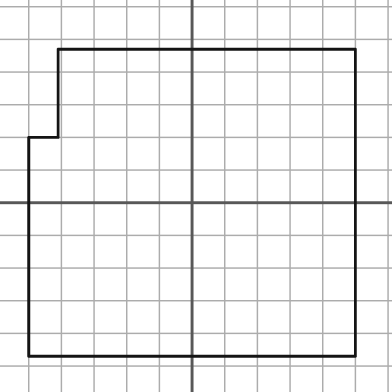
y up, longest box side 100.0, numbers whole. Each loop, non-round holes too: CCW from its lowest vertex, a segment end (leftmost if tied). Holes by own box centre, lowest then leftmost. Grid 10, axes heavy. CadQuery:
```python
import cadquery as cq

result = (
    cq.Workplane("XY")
    .moveTo(-50.0, -47.0)
    .lineTo(50.0, -47.0)
    .lineTo(50.0, 47.0)
    .lineTo(-41.0, 47.0)
    .lineTo(-41.0, 20.0)
    .lineTo(-50.0, 20.0)
    .close()
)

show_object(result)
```